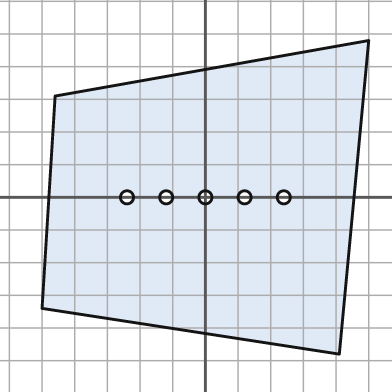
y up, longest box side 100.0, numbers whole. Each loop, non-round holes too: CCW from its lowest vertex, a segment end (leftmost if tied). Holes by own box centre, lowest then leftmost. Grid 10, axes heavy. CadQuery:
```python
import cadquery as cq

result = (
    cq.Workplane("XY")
    .moveTo(41.0, -48.0)
    .lineTo(50.0, 48.0)
    .lineTo(-46.0, 31.0)
    .lineTo(-50.0, -34.0)
    .close()
    .moveTo(-24.0, 0.0)
    .circle(2.0)
    .moveTo(-12.0, 0.0)
    .circle(2.0)
    .moveTo(0.0, 0.0)
    .circle(2.0)
    .moveTo(12.0, 0.0)
    .circle(2.0)
    .moveTo(24.0, 0.0)
    .circle(2.0)
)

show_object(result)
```